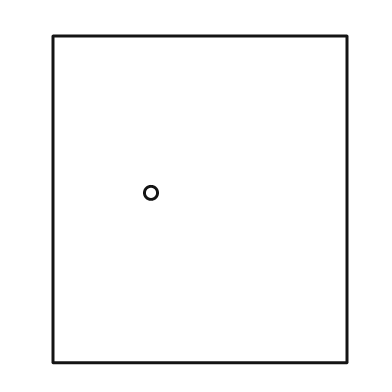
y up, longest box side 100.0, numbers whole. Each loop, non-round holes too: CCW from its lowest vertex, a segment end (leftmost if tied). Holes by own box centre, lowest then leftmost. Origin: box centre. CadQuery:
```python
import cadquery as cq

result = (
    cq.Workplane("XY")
    .moveTo(-45.0, -50.0)
    .lineTo(45.0, -50.0)
    .lineTo(45.0, 50.0)
    .lineTo(-45.0, 50.0)
    .close()
    .moveTo(-15.0, 2.0)
    .circle(2.0)
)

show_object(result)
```